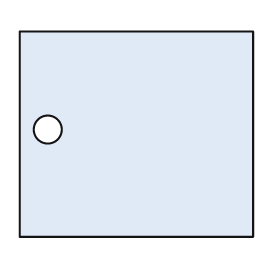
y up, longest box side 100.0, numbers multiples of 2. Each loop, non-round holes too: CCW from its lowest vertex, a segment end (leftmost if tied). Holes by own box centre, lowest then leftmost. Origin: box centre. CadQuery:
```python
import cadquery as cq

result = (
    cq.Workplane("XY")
    .moveTo(-50.0, -44.0)
    .lineTo(50.0, -44.0)
    .lineTo(50.0, 44.0)
    .lineTo(-50.0, 44.0)
    .close()
    .moveTo(-38.0, 2.0)
    .circle(6.0)
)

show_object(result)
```